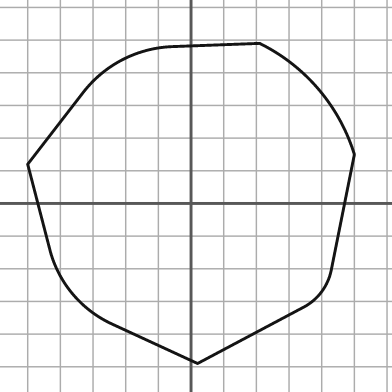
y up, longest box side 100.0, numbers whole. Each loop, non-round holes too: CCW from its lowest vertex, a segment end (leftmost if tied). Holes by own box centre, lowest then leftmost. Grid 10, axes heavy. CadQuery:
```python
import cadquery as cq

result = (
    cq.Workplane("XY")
    .moveTo(2.0, -49.0)
    .lineTo(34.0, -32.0)
    .threePointArc((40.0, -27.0), (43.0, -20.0))
    .lineTo(50.0, 15.0)
    .threePointArc((39.0, 35.0), (21.0, 49.0))
    .lineTo(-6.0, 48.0)
    .threePointArc((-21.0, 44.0), (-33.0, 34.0))
    .lineTo(-50.0, 12.0)
    .lineTo(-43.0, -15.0)
    .threePointArc((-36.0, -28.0), (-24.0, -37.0))
    .close()
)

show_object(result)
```